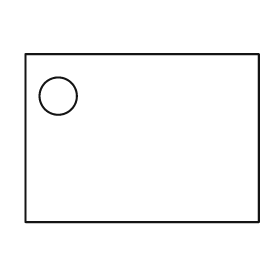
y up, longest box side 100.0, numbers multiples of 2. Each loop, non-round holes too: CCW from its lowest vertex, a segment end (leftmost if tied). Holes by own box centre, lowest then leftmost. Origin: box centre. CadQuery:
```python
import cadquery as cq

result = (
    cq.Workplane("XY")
    .moveTo(-50.0, -36.0)
    .lineTo(50.0, -36.0)
    .lineTo(50.0, 36.0)
    .lineTo(-50.0, 36.0)
    .close()
    .moveTo(-36.0, 18.0)
    .circle(8.0)
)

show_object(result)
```